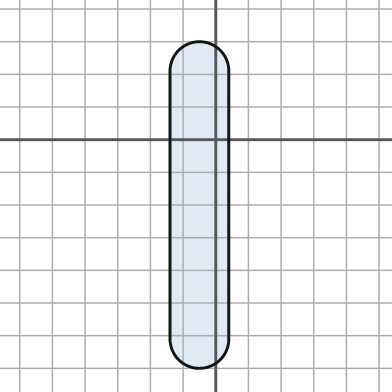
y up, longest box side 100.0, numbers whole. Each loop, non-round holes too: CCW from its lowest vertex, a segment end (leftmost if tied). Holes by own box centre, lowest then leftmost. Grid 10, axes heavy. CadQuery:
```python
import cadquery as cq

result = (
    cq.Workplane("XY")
    .moveTo(-14.0, -61.0)
    .threePointArc((-5.0, -70.0), (4.0, -61.0))
    .lineTo(4.0, 21.0)
    .threePointArc((-5.0, 30.0), (-14.0, 21.0))
    .close()
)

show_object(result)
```